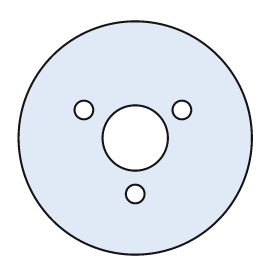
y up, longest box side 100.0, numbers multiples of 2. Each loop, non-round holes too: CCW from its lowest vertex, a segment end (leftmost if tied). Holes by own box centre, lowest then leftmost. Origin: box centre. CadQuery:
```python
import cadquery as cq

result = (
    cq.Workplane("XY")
    .moveTo(0.0, 0.0)
    .circle(50.0)
    .moveTo(0.0, -24.0)
    .circle(4.0)
    .moveTo(0.0, 0.0)
    .circle(14.0)
    .moveTo(-22.0, 12.0)
    .circle(4.0)
    .moveTo(20.0, 12.0)
    .circle(4.0)
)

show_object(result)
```